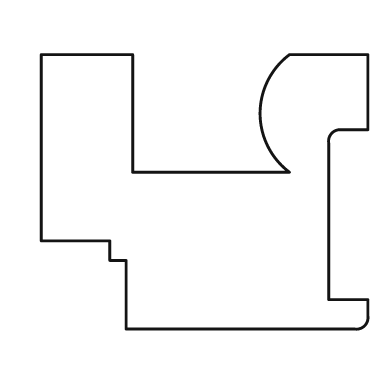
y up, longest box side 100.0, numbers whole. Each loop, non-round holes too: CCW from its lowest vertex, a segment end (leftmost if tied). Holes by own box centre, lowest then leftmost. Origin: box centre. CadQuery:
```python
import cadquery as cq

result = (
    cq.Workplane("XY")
    .moveTo(-24.0, -42.0)
    .lineTo(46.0, -42.0)
    .threePointArc((49.0, -41.0), (50.0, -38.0))
    .lineTo(50.0, -33.0)
    .lineTo(38.0, -33.0)
    .lineTo(38.0, 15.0)
    .threePointArc((39.0, 18.0), (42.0, 19.0))
    .lineTo(50.0, 19.0)
    .lineTo(50.0, 42.0)
    .lineTo(26.0, 42.0)
    .threePointArc((17.0, 24.0), (26.0, 6.0))
    .lineTo(-22.0, 6.0)
    .lineTo(-22.0, 42.0)
    .lineTo(-50.0, 42.0)
    .lineTo(-50.0, -15.0)
    .lineTo(-29.0, -15.0)
    .lineTo(-29.0, -21.0)
    .lineTo(-24.0, -21.0)
    .close()
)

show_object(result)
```